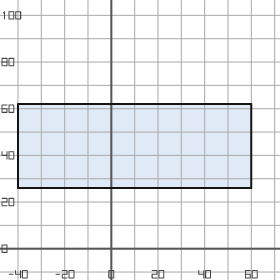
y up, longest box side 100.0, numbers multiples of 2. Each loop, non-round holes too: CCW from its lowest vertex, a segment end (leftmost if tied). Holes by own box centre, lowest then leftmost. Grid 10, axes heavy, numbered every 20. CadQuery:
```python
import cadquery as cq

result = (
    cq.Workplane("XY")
    .moveTo(-40.0, 26.0)
    .lineTo(60.0, 26.0)
    .lineTo(60.0, 62.0)
    .lineTo(-40.0, 62.0)
    .close()
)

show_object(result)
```